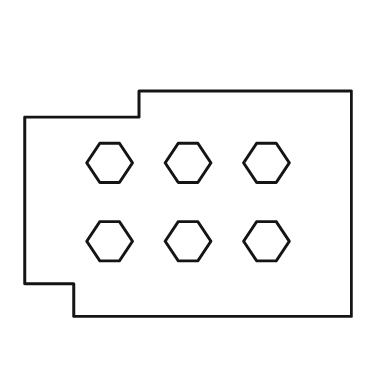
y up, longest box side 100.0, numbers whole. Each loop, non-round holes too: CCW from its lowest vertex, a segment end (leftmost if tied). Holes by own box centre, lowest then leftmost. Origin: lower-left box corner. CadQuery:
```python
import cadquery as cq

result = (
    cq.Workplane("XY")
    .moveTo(15.0, 0.0)
    .lineTo(100.0, 0.0)
    .lineTo(100.0, 69.0)
    .lineTo(35.0, 69.0)
    .lineTo(35.0, 61.0)
    .lineTo(0.0, 61.0)
    .lineTo(0.0, 10.0)
    .lineTo(15.0, 10.0)
    .close()
    .moveTo(23.0, 17.0)
    .lineTo(29.0, 17.0)
    .lineTo(33.0, 23.0)
    .lineTo(29.0, 29.0)
    .lineTo(23.0, 29.0)
    .lineTo(19.0, 23.0)
    .close()
    .moveTo(47.0, 17.0)
    .lineTo(53.0, 17.0)
    .lineTo(57.0, 23.0)
    .lineTo(53.0, 29.0)
    .lineTo(47.0, 29.0)
    .lineTo(43.0, 23.0)
    .close()
    .moveTo(71.0, 17.0)
    .lineTo(77.0, 17.0)
    .lineTo(81.0, 23.0)
    .lineTo(77.0, 29.0)
    .lineTo(71.0, 29.0)
    .lineTo(67.0, 23.0)
    .close()
    .moveTo(23.0, 41.0)
    .lineTo(29.0, 41.0)
    .lineTo(33.0, 47.0)
    .lineTo(29.0, 53.0)
    .lineTo(23.0, 53.0)
    .lineTo(19.0, 47.0)
    .close()
    .moveTo(47.0, 41.0)
    .lineTo(53.0, 41.0)
    .lineTo(57.0, 47.0)
    .lineTo(53.0, 53.0)
    .lineTo(47.0, 53.0)
    .lineTo(43.0, 47.0)
    .close()
    .moveTo(71.0, 41.0)
    .lineTo(77.0, 41.0)
    .lineTo(81.0, 47.0)
    .lineTo(77.0, 53.0)
    .lineTo(71.0, 53.0)
    .lineTo(67.0, 47.0)
    .close()
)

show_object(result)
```